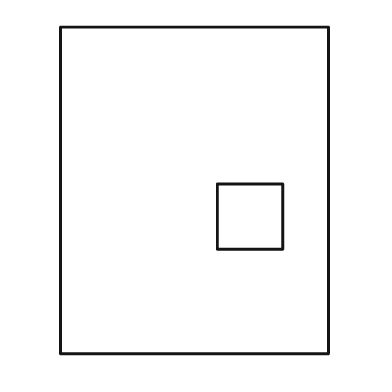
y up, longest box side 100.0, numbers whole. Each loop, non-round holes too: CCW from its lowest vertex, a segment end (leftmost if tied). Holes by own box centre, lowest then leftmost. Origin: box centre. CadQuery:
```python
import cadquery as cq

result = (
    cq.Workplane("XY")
    .moveTo(-41.0, -50.0)
    .lineTo(41.0, -50.0)
    .lineTo(41.0, 50.0)
    .lineTo(-41.0, 50.0)
    .close()
    .moveTo(7.0, -18.0)
    .lineTo(27.0, -18.0)
    .lineTo(27.0, 2.0)
    .lineTo(7.0, 2.0)
    .close()
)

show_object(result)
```